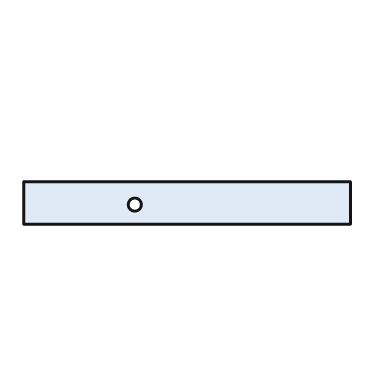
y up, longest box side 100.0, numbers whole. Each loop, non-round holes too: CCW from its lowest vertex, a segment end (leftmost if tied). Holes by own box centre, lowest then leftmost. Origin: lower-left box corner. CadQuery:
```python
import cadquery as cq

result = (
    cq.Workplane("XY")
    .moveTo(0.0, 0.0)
    .lineTo(100.0, 0.0)
    .lineTo(100.0, 13.0)
    .lineTo(0.0, 13.0)
    .close()
    .moveTo(34.0, 6.0)
    .circle(2.0)
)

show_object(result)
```